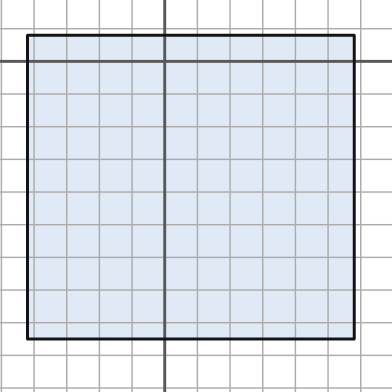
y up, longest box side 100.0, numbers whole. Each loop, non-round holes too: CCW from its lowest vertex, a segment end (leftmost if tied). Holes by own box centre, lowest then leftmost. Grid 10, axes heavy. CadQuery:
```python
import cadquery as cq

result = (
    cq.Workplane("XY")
    .moveTo(-42.0, -85.0)
    .lineTo(58.0, -85.0)
    .lineTo(58.0, 8.0)
    .lineTo(-42.0, 8.0)
    .close()
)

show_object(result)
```